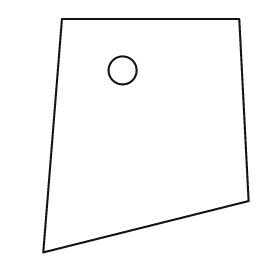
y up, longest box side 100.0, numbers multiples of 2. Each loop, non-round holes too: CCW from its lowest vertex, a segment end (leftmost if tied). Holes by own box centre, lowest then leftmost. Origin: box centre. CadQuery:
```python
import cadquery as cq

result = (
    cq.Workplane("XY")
    .moveTo(-44.0, -50.0)
    .lineTo(44.0, -28.0)
    .lineTo(40.0, 50.0)
    .lineTo(-36.0, 50.0)
    .close()
    .moveTo(-10.0, 28.0)
    .circle(6.0)
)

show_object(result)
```